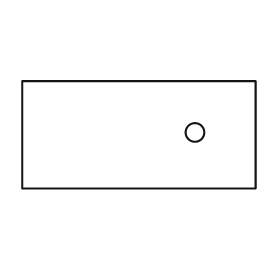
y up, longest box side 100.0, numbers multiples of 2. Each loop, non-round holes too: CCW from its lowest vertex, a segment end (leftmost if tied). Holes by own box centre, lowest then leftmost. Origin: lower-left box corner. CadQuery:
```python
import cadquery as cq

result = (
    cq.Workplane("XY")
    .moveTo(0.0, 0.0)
    .lineTo(100.0, 0.0)
    .lineTo(100.0, 46.0)
    .lineTo(0.0, 46.0)
    .close()
    .moveTo(74.0, 24.0)
    .circle(4.0)
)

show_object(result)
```